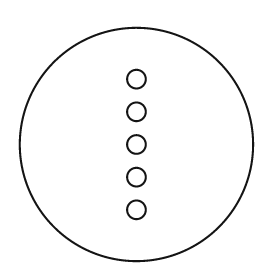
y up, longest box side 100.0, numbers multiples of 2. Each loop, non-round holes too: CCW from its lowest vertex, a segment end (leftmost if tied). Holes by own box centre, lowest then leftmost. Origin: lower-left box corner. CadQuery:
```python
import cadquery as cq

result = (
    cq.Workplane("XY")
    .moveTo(50.0, 50.0)
    .circle(50.0)
    .moveTo(50.0, 22.0)
    .circle(4.0)
    .moveTo(50.0, 36.0)
    .circle(4.0)
    .moveTo(50.0, 50.0)
    .circle(4.0)
    .moveTo(50.0, 64.0)
    .circle(4.0)
    .moveTo(50.0, 78.0)
    .circle(4.0)
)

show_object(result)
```